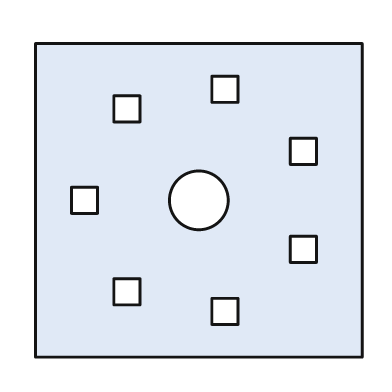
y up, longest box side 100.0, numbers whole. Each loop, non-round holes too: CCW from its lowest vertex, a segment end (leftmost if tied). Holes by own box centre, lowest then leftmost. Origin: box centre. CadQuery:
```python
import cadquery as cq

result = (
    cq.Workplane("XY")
    .moveTo(-50.0, -48.0)
    .lineTo(50.0, -48.0)
    .lineTo(50.0, 48.0)
    .lineTo(-50.0, 48.0)
    .close()
    .moveTo(4.0, -38.0)
    .lineTo(12.0, -38.0)
    .lineTo(12.0, -30.0)
    .lineTo(4.0, -30.0)
    .close()
    .moveTo(-26.0, -32.0)
    .lineTo(-18.0, -32.0)
    .lineTo(-18.0, -24.0)
    .lineTo(-26.0, -24.0)
    .close()
    .moveTo(28.0, -19.0)
    .lineTo(36.0, -19.0)
    .lineTo(36.0, -11.0)
    .lineTo(28.0, -11.0)
    .close()
    .moveTo(-39.0, -4.0)
    .lineTo(-31.0, -4.0)
    .lineTo(-31.0, 4.0)
    .lineTo(-39.0, 4.0)
    .close()
    .moveTo(0.0, 0.0)
    .circle(9.0)
    .moveTo(28.0, 11.0)
    .lineTo(36.0, 11.0)
    .lineTo(36.0, 19.0)
    .lineTo(28.0, 19.0)
    .close()
    .moveTo(-26.0, 24.0)
    .lineTo(-18.0, 24.0)
    .lineTo(-18.0, 32.0)
    .lineTo(-26.0, 32.0)
    .close()
    .moveTo(4.0, 30.0)
    .lineTo(12.0, 30.0)
    .lineTo(12.0, 38.0)
    .lineTo(4.0, 38.0)
    .close()
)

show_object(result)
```